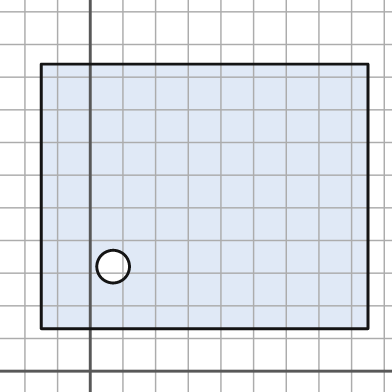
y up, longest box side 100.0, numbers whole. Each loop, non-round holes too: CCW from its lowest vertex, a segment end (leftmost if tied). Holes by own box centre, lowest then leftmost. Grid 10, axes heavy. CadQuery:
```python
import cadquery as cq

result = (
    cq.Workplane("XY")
    .moveTo(-15.0, 13.0)
    .lineTo(85.0, 13.0)
    .lineTo(85.0, 94.0)
    .lineTo(-15.0, 94.0)
    .close()
    .moveTo(7.0, 32.0)
    .circle(5.0)
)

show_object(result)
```